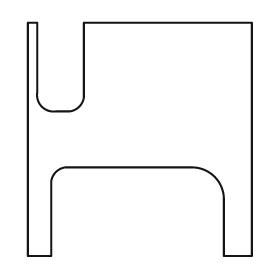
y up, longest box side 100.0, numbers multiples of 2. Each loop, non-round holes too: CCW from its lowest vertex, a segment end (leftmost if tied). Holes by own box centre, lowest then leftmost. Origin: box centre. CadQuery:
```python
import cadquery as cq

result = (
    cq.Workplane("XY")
    .moveTo(-48.0, -50.0)
    .lineTo(-38.0, -50.0)
    .lineTo(-38.0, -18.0)
    .threePointArc((-36.0, -14.0), (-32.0, -12.0))
    .lineTo(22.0, -12.0)
    .threePointArc((32.0, -16.0), (36.0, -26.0))
    .lineTo(36.0, -50.0)
    .lineTo(48.0, -50.0)
    .lineTo(48.0, 50.0)
    .lineTo(-24.0, 50.0)
    .lineTo(-24.0, 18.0)
    .threePointArc((-26.0, 14.0), (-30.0, 12.0))
    .lineTo(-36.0, 12.0)
    .threePointArc((-42.0, 14.0), (-44.0, 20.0))
    .lineTo(-44.0, 50.0)
    .lineTo(-48.0, 50.0)
    .close()
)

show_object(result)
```